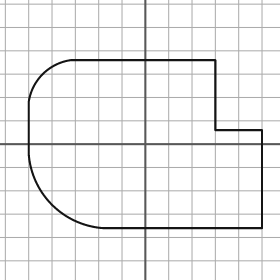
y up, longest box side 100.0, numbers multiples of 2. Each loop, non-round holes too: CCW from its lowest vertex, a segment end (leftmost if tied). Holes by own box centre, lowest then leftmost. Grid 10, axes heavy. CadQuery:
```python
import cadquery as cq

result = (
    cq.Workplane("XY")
    .moveTo(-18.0, -36.0)
    .lineTo(50.0, -36.0)
    .lineTo(50.0, 6.0)
    .lineTo(30.0, 6.0)
    .lineTo(30.0, 36.0)
    .lineTo(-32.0, 36.0)
    .threePointArc((-44.0, 30.0), (-50.0, 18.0))
    .lineTo(-50.0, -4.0)
    .threePointArc((-40.0, -26.0), (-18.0, -36.0))
    .close()
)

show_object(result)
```